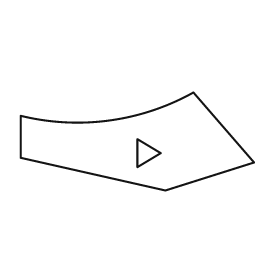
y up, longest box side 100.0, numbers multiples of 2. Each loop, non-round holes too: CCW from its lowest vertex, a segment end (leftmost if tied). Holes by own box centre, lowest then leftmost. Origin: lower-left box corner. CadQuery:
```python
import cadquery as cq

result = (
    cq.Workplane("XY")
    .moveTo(62.0, 0.0)
    .lineTo(100.0, 12.0)
    .lineTo(74.0, 42.0)
    .threePointArc((38.0, 30.0), (0.0, 32.0))
    .lineTo(0.0, 14.0)
    .close()
    .moveTo(50.0, 10.0)
    .lineTo(60.0, 16.0)
    .lineTo(50.0, 22.0)
    .close()
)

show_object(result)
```